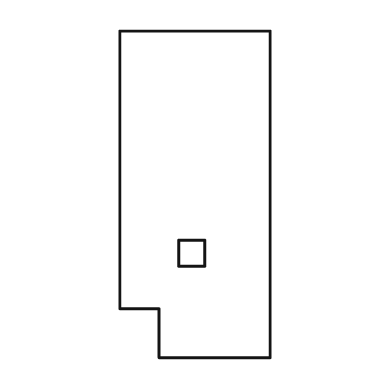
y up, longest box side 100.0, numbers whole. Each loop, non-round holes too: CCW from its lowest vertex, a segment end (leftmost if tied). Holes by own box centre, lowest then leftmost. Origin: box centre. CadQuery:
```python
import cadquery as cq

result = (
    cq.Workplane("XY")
    .moveTo(-11.0, -50.0)
    .lineTo(23.0, -50.0)
    .lineTo(23.0, 50.0)
    .lineTo(-23.0, 50.0)
    .lineTo(-23.0, -35.0)
    .lineTo(-11.0, -35.0)
    .close()
    .moveTo(-5.0, -22.0)
    .lineTo(3.0, -22.0)
    .lineTo(3.0, -14.0)
    .lineTo(-5.0, -14.0)
    .close()
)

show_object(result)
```